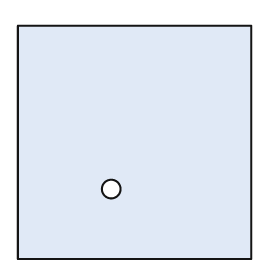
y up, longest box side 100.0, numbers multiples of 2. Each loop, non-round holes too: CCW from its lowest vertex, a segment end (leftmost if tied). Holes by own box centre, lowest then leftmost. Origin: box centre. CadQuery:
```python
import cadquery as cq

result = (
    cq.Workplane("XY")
    .moveTo(-50.0, -50.0)
    .lineTo(50.0, -50.0)
    .lineTo(50.0, 50.0)
    .lineTo(-50.0, 50.0)
    .close()
    .moveTo(-10.0, -20.0)
    .circle(4.0)
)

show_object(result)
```